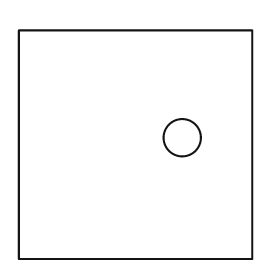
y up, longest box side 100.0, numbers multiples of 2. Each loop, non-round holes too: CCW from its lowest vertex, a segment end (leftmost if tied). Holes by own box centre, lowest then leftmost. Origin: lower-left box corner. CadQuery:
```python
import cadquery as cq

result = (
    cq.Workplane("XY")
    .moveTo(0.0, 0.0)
    .lineTo(100.0, 0.0)
    .lineTo(100.0, 98.0)
    .lineTo(0.0, 98.0)
    .close()
    .moveTo(70.0, 52.0)
    .circle(8.0)
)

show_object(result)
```